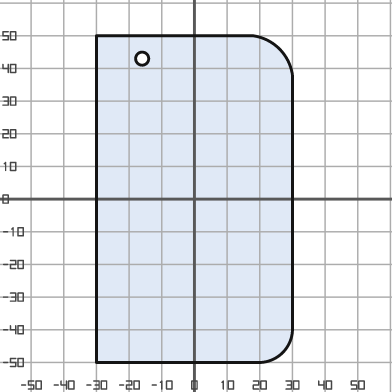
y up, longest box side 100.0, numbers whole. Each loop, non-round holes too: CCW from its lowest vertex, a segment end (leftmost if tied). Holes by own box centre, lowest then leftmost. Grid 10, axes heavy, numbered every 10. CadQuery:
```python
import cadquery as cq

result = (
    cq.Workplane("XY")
    .moveTo(-30.0, -50.0)
    .lineTo(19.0, -50.0)
    .threePointArc((27.0, -47.0), (30.0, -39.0))
    .lineTo(30.0, 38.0)
    .threePointArc((26.0, 46.0), (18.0, 50.0))
    .lineTo(-30.0, 50.0)
    .close()
    .moveTo(-16.0, 43.0)
    .circle(2.0)
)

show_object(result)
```